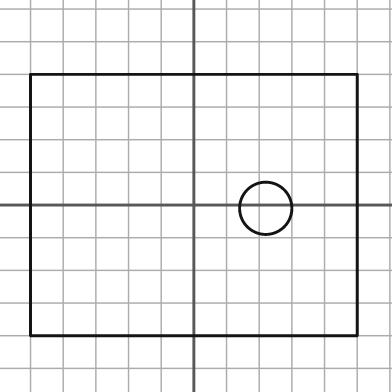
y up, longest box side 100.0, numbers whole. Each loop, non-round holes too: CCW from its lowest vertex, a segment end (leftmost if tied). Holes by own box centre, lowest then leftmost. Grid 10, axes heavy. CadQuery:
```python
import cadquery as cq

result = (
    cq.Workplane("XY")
    .moveTo(-50.0, -40.0)
    .lineTo(50.0, -40.0)
    .lineTo(50.0, 40.0)
    .lineTo(-50.0, 40.0)
    .close()
    .moveTo(22.0, -1.0)
    .circle(8.0)
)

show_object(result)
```